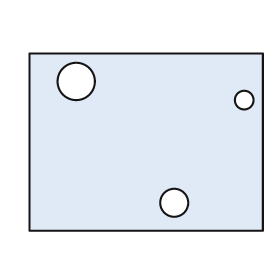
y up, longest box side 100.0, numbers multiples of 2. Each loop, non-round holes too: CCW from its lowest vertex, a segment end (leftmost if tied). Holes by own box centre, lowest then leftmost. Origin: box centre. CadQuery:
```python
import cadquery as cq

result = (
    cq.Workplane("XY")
    .moveTo(-50.0, -38.0)
    .lineTo(50.0, -38.0)
    .lineTo(50.0, 38.0)
    .lineTo(-50.0, 38.0)
    .close()
    .moveTo(12.0, -26.0)
    .circle(6.0)
    .moveTo(42.0, 18.0)
    .circle(4.0)
    .moveTo(-30.0, 26.0)
    .circle(8.0)
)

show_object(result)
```